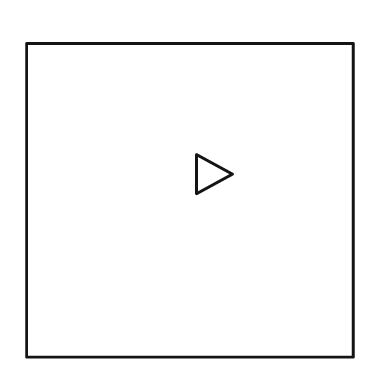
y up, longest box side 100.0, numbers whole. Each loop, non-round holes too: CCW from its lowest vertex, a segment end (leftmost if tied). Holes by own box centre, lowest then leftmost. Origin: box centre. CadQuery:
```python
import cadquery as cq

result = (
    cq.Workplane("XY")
    .moveTo(-50.0, -48.0)
    .lineTo(50.0, -48.0)
    .lineTo(50.0, 48.0)
    .lineTo(-50.0, 48.0)
    .close()
    .moveTo(2.0, 2.0)
    .lineTo(13.0, 8.0)
    .lineTo(2.0, 14.0)
    .close()
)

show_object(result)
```